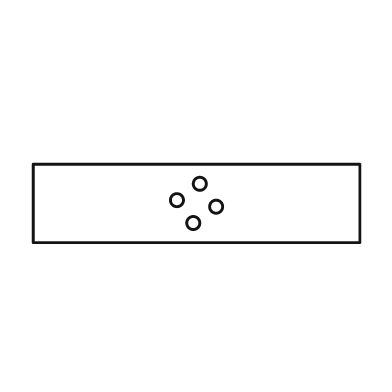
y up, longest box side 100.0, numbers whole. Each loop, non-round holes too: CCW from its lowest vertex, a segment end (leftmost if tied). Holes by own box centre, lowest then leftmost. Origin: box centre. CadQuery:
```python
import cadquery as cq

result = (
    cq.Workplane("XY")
    .moveTo(-50.0, -12.0)
    .lineTo(50.0, -12.0)
    .lineTo(50.0, 12.0)
    .lineTo(-50.0, 12.0)
    .close()
    .moveTo(-1.0, -6.0)
    .circle(2.0)
    .moveTo(6.0, -1.0)
    .circle(2.0)
    .moveTo(-6.0, 1.0)
    .circle(2.0)
    .moveTo(1.0, 6.0)
    .circle(2.0)
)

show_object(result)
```